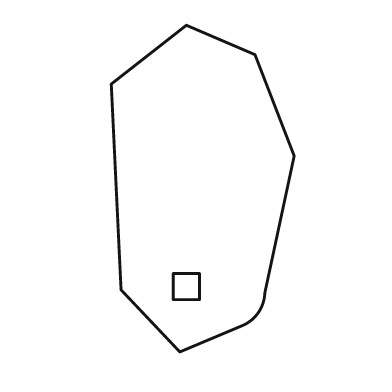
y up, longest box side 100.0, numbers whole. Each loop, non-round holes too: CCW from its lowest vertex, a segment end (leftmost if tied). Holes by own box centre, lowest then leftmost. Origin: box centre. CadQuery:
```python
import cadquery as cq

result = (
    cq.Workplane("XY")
    .moveTo(-7.0, -50.0)
    .lineTo(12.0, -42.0)
    .threePointArc((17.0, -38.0), (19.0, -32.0))
    .lineTo(28.0, 10.0)
    .lineTo(16.0, 41.0)
    .lineTo(-5.0, 50.0)
    .lineTo(-28.0, 32.0)
    .lineTo(-25.0, -31.0)
    .close()
    .moveTo(-9.0, -34.0)
    .lineTo(-1.0, -34.0)
    .lineTo(-1.0, -26.0)
    .lineTo(-9.0, -26.0)
    .close()
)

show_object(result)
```